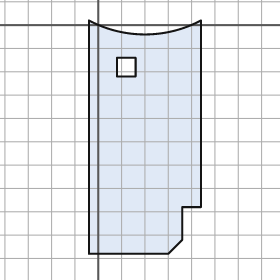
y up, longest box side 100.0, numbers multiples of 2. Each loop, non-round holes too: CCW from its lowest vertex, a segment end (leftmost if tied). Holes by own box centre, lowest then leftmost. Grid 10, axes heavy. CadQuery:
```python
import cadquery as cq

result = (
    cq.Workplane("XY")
    .moveTo(-4.0, -98.0)
    .lineTo(30.0, -98.0)
    .lineTo(36.0, -92.0)
    .lineTo(36.0, -78.0)
    .lineTo(44.0, -78.0)
    .lineTo(44.0, 2.0)
    .threePointArc((20.0, -4.0), (-4.0, 2.0))
    .close()
    .moveTo(8.0, -22.0)
    .lineTo(16.0, -22.0)
    .lineTo(16.0, -14.0)
    .lineTo(8.0, -14.0)
    .close()
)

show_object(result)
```